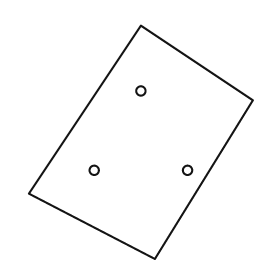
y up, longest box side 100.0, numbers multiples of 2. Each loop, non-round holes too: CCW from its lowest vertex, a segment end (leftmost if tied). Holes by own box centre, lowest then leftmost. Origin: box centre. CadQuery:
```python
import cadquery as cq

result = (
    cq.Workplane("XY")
    .moveTo(6.0, -50.0)
    .lineTo(48.0, 18.0)
    .lineTo(0.0, 50.0)
    .lineTo(-48.0, -22.0)
    .close()
    .moveTo(-20.0, -12.0)
    .circle(2.0)
    .moveTo(20.0, -12.0)
    .circle(2.0)
    .moveTo(0.0, 22.0)
    .circle(2.0)
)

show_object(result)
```